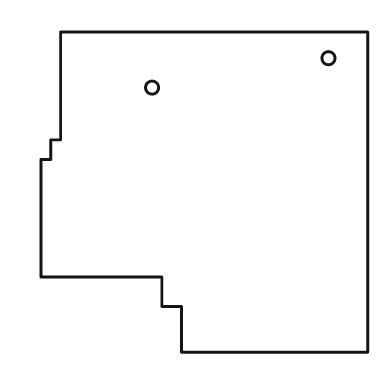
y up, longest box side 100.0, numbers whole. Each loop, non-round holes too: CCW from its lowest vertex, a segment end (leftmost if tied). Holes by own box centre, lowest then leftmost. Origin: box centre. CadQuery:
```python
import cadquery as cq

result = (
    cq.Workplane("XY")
    .moveTo(-7.0, -49.0)
    .lineTo(50.0, -49.0)
    .lineTo(50.0, 49.0)
    .lineTo(-44.0, 49.0)
    .lineTo(-44.0, 16.0)
    .lineTo(-47.0, 16.0)
    .lineTo(-47.0, 10.0)
    .lineTo(-50.0, 10.0)
    .lineTo(-50.0, -26.0)
    .lineTo(-13.0, -26.0)
    .lineTo(-13.0, -35.0)
    .lineTo(-7.0, -35.0)
    .close()
    .moveTo(-16.0, 32.0)
    .circle(2.0)
    .moveTo(38.0, 41.0)
    .circle(2.0)
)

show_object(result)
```